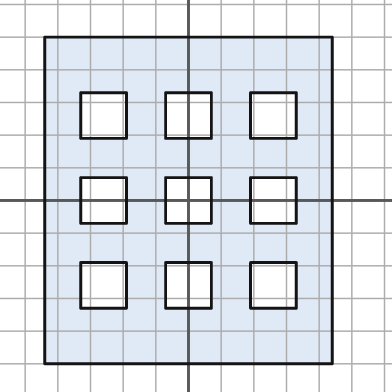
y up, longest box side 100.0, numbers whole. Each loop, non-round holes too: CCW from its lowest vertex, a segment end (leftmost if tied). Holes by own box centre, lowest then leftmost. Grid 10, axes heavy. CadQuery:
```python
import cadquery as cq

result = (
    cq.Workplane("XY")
    .moveTo(-44.0, -50.0)
    .lineTo(44.0, -50.0)
    .lineTo(44.0, 50.0)
    .lineTo(-44.0, 50.0)
    .close()
    .moveTo(-33.0, -33.0)
    .lineTo(-19.0, -33.0)
    .lineTo(-19.0, -19.0)
    .lineTo(-33.0, -19.0)
    .close()
    .moveTo(-7.0, -33.0)
    .lineTo(7.0, -33.0)
    .lineTo(7.0, -19.0)
    .lineTo(-7.0, -19.0)
    .close()
    .moveTo(19.0, -33.0)
    .lineTo(33.0, -33.0)
    .lineTo(33.0, -19.0)
    .lineTo(19.0, -19.0)
    .close()
    .moveTo(-33.0, -7.0)
    .lineTo(-19.0, -7.0)
    .lineTo(-19.0, 7.0)
    .lineTo(-33.0, 7.0)
    .close()
    .moveTo(-7.0, -7.0)
    .lineTo(7.0, -7.0)
    .lineTo(7.0, 7.0)
    .lineTo(-7.0, 7.0)
    .close()
    .moveTo(19.0, -7.0)
    .lineTo(33.0, -7.0)
    .lineTo(33.0, 7.0)
    .lineTo(19.0, 7.0)
    .close()
    .moveTo(-33.0, 19.0)
    .lineTo(-19.0, 19.0)
    .lineTo(-19.0, 33.0)
    .lineTo(-33.0, 33.0)
    .close()
    .moveTo(-7.0, 19.0)
    .lineTo(7.0, 19.0)
    .lineTo(7.0, 33.0)
    .lineTo(-7.0, 33.0)
    .close()
    .moveTo(19.0, 19.0)
    .lineTo(33.0, 19.0)
    .lineTo(33.0, 33.0)
    .lineTo(19.0, 33.0)
    .close()
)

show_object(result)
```